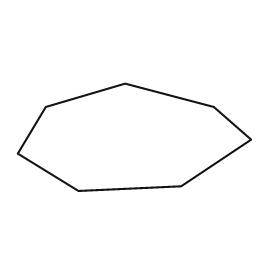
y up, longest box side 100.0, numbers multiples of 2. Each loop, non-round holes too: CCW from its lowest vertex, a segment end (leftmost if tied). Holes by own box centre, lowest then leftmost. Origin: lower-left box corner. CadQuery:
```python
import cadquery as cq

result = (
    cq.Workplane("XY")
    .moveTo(26.0, 0.0)
    .lineTo(70.0, 2.0)
    .lineTo(100.0, 22.0)
    .lineTo(84.0, 36.0)
    .lineTo(46.0, 46.0)
    .lineTo(12.0, 36.0)
    .lineTo(0.0, 16.0)
    .close()
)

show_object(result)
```